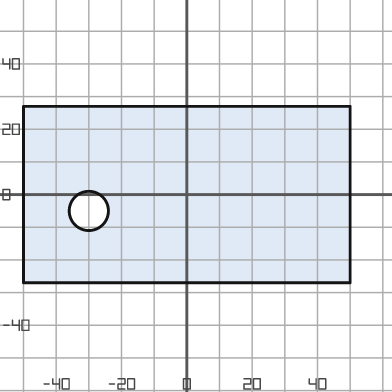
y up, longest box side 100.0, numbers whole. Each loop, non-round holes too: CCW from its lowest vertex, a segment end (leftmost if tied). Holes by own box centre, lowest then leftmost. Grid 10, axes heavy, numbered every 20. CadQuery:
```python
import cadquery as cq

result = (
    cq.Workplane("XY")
    .moveTo(-50.0, -27.0)
    .lineTo(50.0, -27.0)
    .lineTo(50.0, 27.0)
    .lineTo(-50.0, 27.0)
    .close()
    .moveTo(-30.0, -5.0)
    .circle(6.0)
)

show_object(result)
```